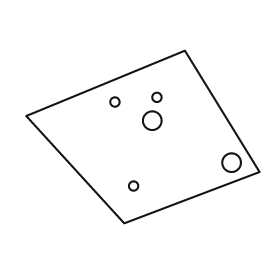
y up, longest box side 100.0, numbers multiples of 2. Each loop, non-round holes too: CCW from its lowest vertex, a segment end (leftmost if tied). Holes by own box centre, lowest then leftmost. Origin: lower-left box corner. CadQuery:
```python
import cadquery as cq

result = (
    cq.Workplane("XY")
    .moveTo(42.0, 0.0)
    .lineTo(100.0, 22.0)
    .lineTo(68.0, 74.0)
    .lineTo(0.0, 46.0)
    .close()
    .moveTo(46.0, 16.0)
    .circle(2.0)
    .moveTo(88.0, 26.0)
    .circle(4.0)
    .moveTo(54.0, 44.0)
    .circle(4.0)
    .moveTo(38.0, 52.0)
    .circle(2.0)
    .moveTo(56.0, 54.0)
    .circle(2.0)
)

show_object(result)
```